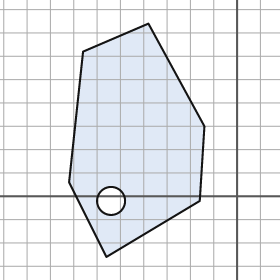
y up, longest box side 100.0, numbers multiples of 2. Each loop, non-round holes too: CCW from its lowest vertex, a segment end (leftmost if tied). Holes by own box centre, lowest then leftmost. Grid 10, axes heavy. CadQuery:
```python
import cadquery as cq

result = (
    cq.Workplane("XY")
    .moveTo(-56.0, -26.0)
    .lineTo(-16.0, -2.0)
    .lineTo(-14.0, 30.0)
    .lineTo(-38.0, 74.0)
    .lineTo(-66.0, 62.0)
    .lineTo(-72.0, 6.0)
    .close()
    .moveTo(-54.0, -2.0)
    .circle(6.0)
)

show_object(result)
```